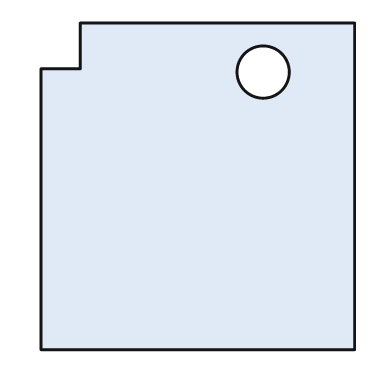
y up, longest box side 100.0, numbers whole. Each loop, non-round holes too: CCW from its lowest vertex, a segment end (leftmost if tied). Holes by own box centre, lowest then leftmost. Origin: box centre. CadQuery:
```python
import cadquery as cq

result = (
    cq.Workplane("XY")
    .moveTo(-48.0, -50.0)
    .lineTo(48.0, -50.0)
    .lineTo(48.0, 50.0)
    .lineTo(-36.0, 50.0)
    .lineTo(-36.0, 36.0)
    .lineTo(-48.0, 36.0)
    .close()
    .moveTo(20.0, 35.0)
    .circle(8.0)
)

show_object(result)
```